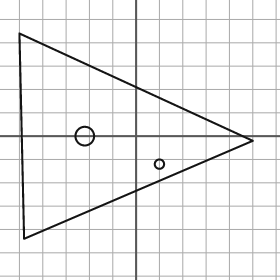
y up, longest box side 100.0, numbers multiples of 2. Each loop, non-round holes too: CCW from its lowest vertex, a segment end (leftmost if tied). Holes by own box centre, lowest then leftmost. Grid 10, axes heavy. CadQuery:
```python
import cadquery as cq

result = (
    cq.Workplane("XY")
    .moveTo(-48.0, -44.0)
    .lineTo(50.0, -2.0)
    .lineTo(-50.0, 44.0)
    .close()
    .moveTo(10.0, -12.0)
    .circle(2.0)
    .moveTo(-22.0, 0.0)
    .circle(4.0)
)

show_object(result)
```